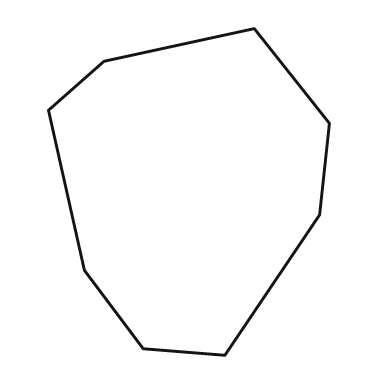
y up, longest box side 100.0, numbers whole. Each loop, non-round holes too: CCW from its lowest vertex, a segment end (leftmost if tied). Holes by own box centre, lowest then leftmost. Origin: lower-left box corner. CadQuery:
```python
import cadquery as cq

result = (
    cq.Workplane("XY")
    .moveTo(54.0, 0.0)
    .lineTo(83.0, 43.0)
    .lineTo(86.0, 71.0)
    .lineTo(63.0, 100.0)
    .lineTo(17.0, 90.0)
    .lineTo(0.0, 75.0)
    .lineTo(11.0, 26.0)
    .lineTo(29.0, 2.0)
    .close()
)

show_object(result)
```